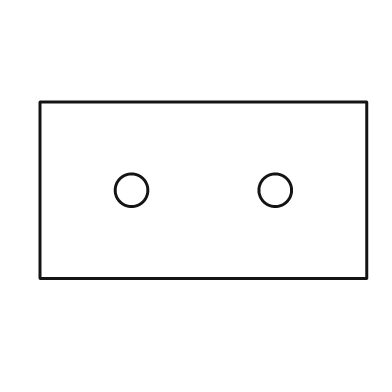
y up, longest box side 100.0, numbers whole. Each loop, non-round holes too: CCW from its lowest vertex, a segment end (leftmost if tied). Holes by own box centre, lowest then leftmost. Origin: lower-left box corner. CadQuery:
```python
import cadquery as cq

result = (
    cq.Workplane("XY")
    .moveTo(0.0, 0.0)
    .lineTo(100.0, 0.0)
    .lineTo(100.0, 54.0)
    .lineTo(0.0, 54.0)
    .close()
    .moveTo(28.0, 27.0)
    .circle(5.0)
    .moveTo(72.0, 27.0)
    .circle(5.0)
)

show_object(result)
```